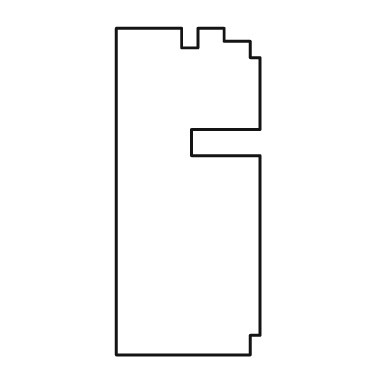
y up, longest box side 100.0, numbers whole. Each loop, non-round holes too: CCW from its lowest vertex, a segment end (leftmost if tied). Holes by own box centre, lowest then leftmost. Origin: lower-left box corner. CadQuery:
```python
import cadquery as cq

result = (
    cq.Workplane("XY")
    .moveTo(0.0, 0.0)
    .lineTo(41.0, 0.0)
    .lineTo(41.0, 6.0)
    .lineTo(44.0, 6.0)
    .lineTo(44.0, 61.0)
    .lineTo(23.0, 61.0)
    .lineTo(23.0, 69.0)
    .lineTo(44.0, 69.0)
    .lineTo(44.0, 91.0)
    .lineTo(41.0, 91.0)
    .lineTo(41.0, 96.0)
    .lineTo(33.0, 96.0)
    .lineTo(33.0, 100.0)
    .lineTo(25.0, 100.0)
    .lineTo(25.0, 94.0)
    .lineTo(20.0, 94.0)
    .lineTo(20.0, 100.0)
    .lineTo(0.0, 100.0)
    .close()
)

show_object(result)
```